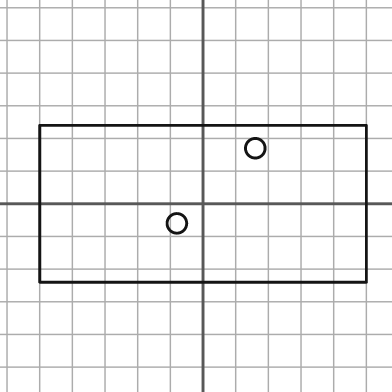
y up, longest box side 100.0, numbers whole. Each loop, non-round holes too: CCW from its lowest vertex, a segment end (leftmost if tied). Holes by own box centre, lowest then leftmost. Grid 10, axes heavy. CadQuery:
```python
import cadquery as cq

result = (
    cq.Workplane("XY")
    .moveTo(-50.0, -24.0)
    .lineTo(50.0, -24.0)
    .lineTo(50.0, 24.0)
    .lineTo(-50.0, 24.0)
    .close()
    .moveTo(-8.0, -6.0)
    .circle(3.0)
    .moveTo(16.0, 17.0)
    .circle(3.0)
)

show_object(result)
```